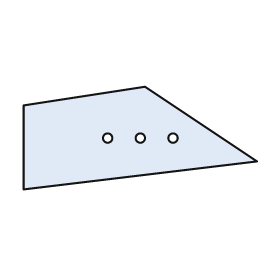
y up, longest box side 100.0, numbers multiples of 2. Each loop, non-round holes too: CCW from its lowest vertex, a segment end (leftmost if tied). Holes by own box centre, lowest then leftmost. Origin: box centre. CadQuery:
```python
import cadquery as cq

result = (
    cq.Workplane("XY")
    .moveTo(-50.0, -22.0)
    .lineTo(50.0, -10.0)
    .lineTo(2.0, 22.0)
    .lineTo(-50.0, 14.0)
    .close()
    .moveTo(-14.0, 0.0)
    .circle(2.0)
    .moveTo(0.0, 0.0)
    .circle(2.0)
    .moveTo(14.0, 0.0)
    .circle(2.0)
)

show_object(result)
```